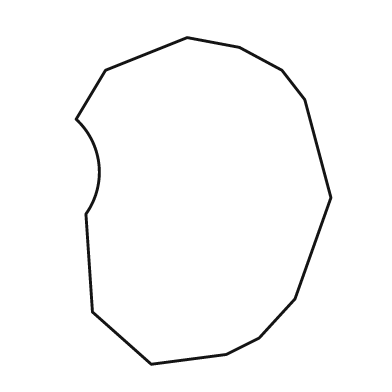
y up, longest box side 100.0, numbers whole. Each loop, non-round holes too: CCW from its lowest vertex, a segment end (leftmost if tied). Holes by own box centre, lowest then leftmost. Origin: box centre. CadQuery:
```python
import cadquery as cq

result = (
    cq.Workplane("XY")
    .moveTo(-16.0, -50.0)
    .lineTo(7.0, -47.0)
    .lineTo(17.0, -42.0)
    .lineTo(28.0, -30.0)
    .lineTo(39.0, 1.0)
    .lineTo(31.0, 31.0)
    .lineTo(24.0, 40.0)
    .lineTo(11.0, 47.0)
    .lineTo(-5.0, 50.0)
    .lineTo(-30.0, 40.0)
    .lineTo(-39.0, 25.0)
    .threePointArc((-32.0, 11.0), (-36.0, -4.0))
    .lineTo(-34.0, -34.0)
    .close()
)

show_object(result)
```